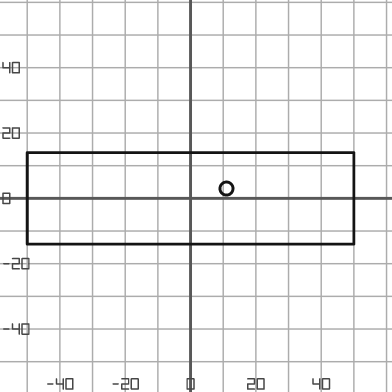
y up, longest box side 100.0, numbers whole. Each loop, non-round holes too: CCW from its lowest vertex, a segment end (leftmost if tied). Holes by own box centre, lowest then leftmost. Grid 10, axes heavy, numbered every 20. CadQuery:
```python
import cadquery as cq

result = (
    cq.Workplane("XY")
    .moveTo(-50.0, -14.0)
    .lineTo(50.0, -14.0)
    .lineTo(50.0, 14.0)
    .lineTo(-50.0, 14.0)
    .close()
    .moveTo(11.0, 3.0)
    .circle(2.0)
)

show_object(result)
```